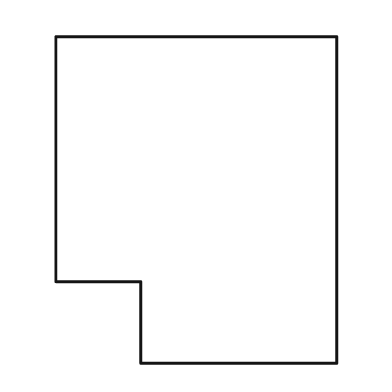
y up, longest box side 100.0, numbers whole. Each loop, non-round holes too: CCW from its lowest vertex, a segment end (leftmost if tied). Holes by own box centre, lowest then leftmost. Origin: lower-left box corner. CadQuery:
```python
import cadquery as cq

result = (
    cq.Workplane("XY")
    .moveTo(26.0, 0.0)
    .lineTo(86.0, 0.0)
    .lineTo(86.0, 100.0)
    .lineTo(0.0, 100.0)
    .lineTo(0.0, 25.0)
    .lineTo(26.0, 25.0)
    .close()
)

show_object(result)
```